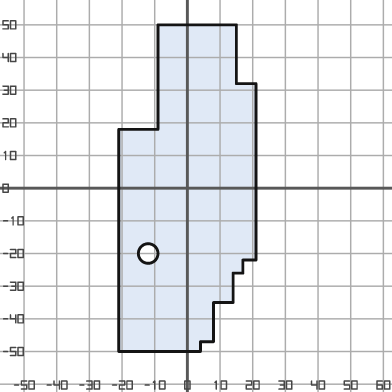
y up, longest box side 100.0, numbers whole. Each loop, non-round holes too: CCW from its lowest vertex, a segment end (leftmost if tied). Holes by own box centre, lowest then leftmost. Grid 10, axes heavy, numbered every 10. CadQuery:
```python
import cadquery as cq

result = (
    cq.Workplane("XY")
    .moveTo(-21.0, -50.0)
    .lineTo(4.0, -50.0)
    .lineTo(4.0, -47.0)
    .lineTo(8.0, -47.0)
    .lineTo(8.0, -35.0)
    .lineTo(14.0, -35.0)
    .lineTo(14.0, -26.0)
    .lineTo(17.0, -26.0)
    .lineTo(17.0, -22.0)
    .lineTo(21.0, -22.0)
    .lineTo(21.0, 32.0)
    .lineTo(15.0, 32.0)
    .lineTo(15.0, 50.0)
    .lineTo(-9.0, 50.0)
    .lineTo(-9.0, 18.0)
    .lineTo(-21.0, 18.0)
    .close()
    .moveTo(-12.0, -20.0)
    .circle(3.0)
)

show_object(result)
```